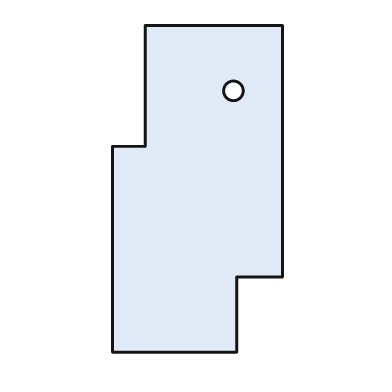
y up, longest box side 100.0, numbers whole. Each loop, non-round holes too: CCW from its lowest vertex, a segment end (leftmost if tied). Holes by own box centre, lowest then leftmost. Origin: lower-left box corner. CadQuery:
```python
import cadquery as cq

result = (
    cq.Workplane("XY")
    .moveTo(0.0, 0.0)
    .lineTo(38.0, 0.0)
    .lineTo(38.0, 23.0)
    .lineTo(52.0, 23.0)
    .lineTo(52.0, 100.0)
    .lineTo(10.0, 100.0)
    .lineTo(10.0, 63.0)
    .lineTo(0.0, 63.0)
    .close()
    .moveTo(37.0, 80.0)
    .circle(3.0)
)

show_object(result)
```